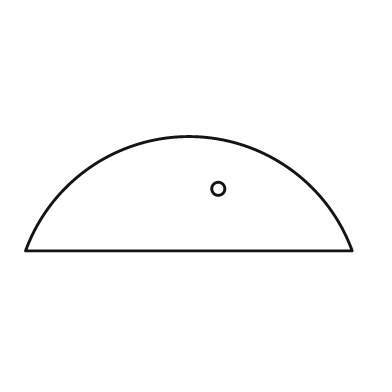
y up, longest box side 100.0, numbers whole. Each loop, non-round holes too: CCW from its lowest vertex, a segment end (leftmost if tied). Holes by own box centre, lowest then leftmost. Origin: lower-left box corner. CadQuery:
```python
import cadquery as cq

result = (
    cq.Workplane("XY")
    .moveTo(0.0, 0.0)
    .lineTo(100.0, 0.0)
    .threePointArc((50.0, 35.0), (0.0, 0.0))
    .close()
    .moveTo(59.0, 19.0)
    .circle(2.0)
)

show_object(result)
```